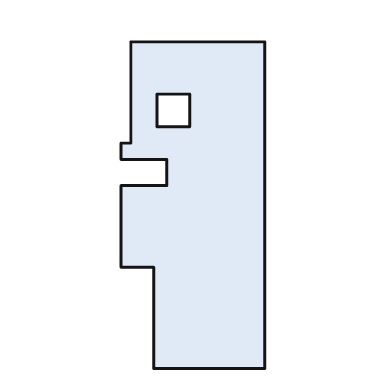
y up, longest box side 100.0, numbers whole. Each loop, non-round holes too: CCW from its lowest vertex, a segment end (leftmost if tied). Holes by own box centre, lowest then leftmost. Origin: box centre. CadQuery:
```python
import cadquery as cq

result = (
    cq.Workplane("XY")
    .moveTo(-12.0, -50.0)
    .lineTo(22.0, -50.0)
    .lineTo(22.0, 50.0)
    .lineTo(-19.0, 50.0)
    .lineTo(-19.0, 19.0)
    .lineTo(-22.0, 19.0)
    .lineTo(-22.0, 14.0)
    .lineTo(-8.0, 14.0)
    .lineTo(-8.0, 6.0)
    .lineTo(-22.0, 6.0)
    .lineTo(-22.0, -19.0)
    .lineTo(-12.0, -19.0)
    .close()
    .moveTo(-11.0, 24.0)
    .lineTo(-1.0, 24.0)
    .lineTo(-1.0, 34.0)
    .lineTo(-11.0, 34.0)
    .close()
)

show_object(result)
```